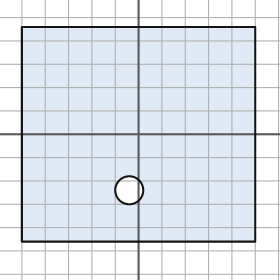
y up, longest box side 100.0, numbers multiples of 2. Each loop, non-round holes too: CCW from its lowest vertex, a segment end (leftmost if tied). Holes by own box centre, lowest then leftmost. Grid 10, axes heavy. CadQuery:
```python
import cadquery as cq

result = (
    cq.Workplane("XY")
    .moveTo(-50.0, -46.0)
    .lineTo(50.0, -46.0)
    .lineTo(50.0, 46.0)
    .lineTo(-50.0, 46.0)
    .close()
    .moveTo(-4.0, -24.0)
    .circle(6.0)
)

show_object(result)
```